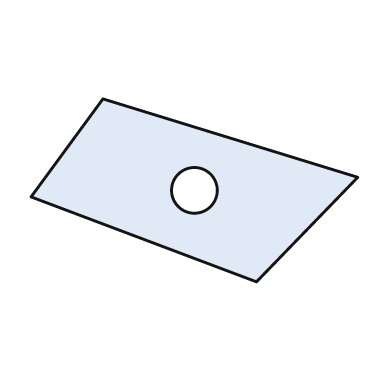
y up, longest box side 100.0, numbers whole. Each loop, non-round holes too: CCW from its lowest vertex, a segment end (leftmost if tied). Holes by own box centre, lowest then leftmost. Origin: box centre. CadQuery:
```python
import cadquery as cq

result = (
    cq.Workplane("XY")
    .moveTo(19.0, -28.0)
    .lineTo(50.0, 4.0)
    .lineTo(-28.0, 28.0)
    .lineTo(-50.0, -2.0)
    .close()
    .moveTo(0.0, 0.0)
    .circle(7.0)
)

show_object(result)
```